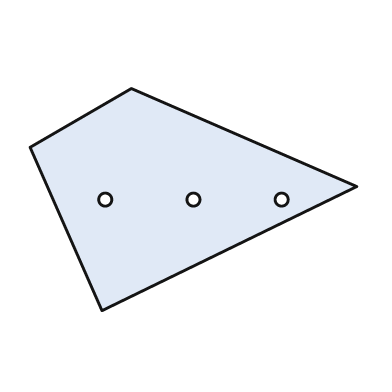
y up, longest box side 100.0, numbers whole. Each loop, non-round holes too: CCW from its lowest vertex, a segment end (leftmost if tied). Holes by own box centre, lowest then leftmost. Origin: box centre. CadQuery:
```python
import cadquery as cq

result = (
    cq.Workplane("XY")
    .moveTo(-28.0, -34.0)
    .lineTo(50.0, 4.0)
    .lineTo(-19.0, 34.0)
    .lineTo(-50.0, 16.0)
    .close()
    .moveTo(-27.0, 0.0)
    .circle(2.0)
    .moveTo(0.0, 0.0)
    .circle(2.0)
    .moveTo(27.0, 0.0)
    .circle(2.0)
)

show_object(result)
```